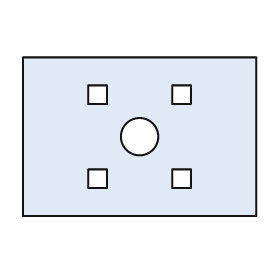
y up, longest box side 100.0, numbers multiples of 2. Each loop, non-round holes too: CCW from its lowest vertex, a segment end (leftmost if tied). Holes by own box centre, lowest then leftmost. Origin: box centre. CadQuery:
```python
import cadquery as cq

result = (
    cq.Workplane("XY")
    .moveTo(-50.0, -34.0)
    .lineTo(50.0, -34.0)
    .lineTo(50.0, 34.0)
    .lineTo(-50.0, 34.0)
    .close()
    .moveTo(-22.0, -22.0)
    .lineTo(-14.0, -22.0)
    .lineTo(-14.0, -14.0)
    .lineTo(-22.0, -14.0)
    .close()
    .moveTo(14.0, -22.0)
    .lineTo(22.0, -22.0)
    .lineTo(22.0, -14.0)
    .lineTo(14.0, -14.0)
    .close()
    .moveTo(0.0, 0.0)
    .circle(8.0)
    .moveTo(-22.0, 14.0)
    .lineTo(-14.0, 14.0)
    .lineTo(-14.0, 22.0)
    .lineTo(-22.0, 22.0)
    .close()
    .moveTo(14.0, 14.0)
    .lineTo(22.0, 14.0)
    .lineTo(22.0, 22.0)
    .lineTo(14.0, 22.0)
    .close()
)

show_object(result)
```